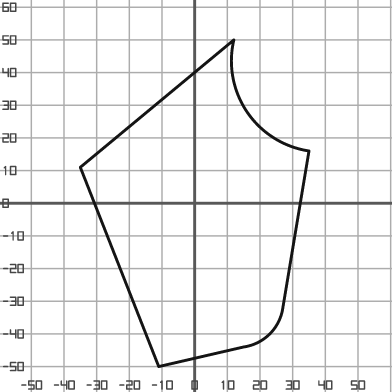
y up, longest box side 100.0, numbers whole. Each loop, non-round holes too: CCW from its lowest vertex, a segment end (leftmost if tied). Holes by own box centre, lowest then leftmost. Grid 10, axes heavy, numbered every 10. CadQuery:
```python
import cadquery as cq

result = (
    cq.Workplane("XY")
    .moveTo(-11.0, -50.0)
    .lineTo(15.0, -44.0)
    .threePointArc((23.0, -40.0), (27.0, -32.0))
    .lineTo(35.0, 16.0)
    .threePointArc((16.0, 28.0), (12.0, 50.0))
    .lineTo(-35.0, 11.0)
    .close()
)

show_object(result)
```